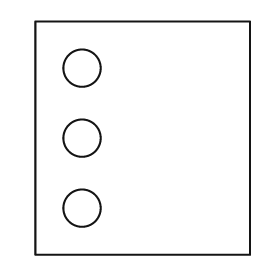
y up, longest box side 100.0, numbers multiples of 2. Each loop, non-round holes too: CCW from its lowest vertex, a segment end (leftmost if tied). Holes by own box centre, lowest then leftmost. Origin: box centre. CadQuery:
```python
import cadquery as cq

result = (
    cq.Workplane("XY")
    .moveTo(-46.0, -50.0)
    .lineTo(46.0, -50.0)
    .lineTo(46.0, 50.0)
    .lineTo(-46.0, 50.0)
    .close()
    .moveTo(-26.0, -30.0)
    .circle(8.0)
    .moveTo(-26.0, 0.0)
    .circle(8.0)
    .moveTo(-26.0, 30.0)
    .circle(8.0)
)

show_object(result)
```